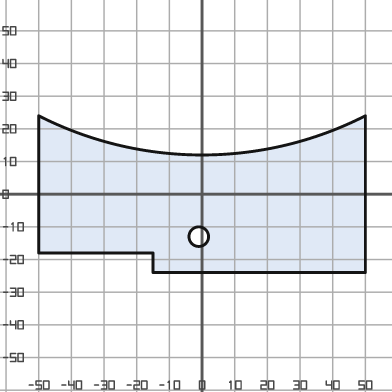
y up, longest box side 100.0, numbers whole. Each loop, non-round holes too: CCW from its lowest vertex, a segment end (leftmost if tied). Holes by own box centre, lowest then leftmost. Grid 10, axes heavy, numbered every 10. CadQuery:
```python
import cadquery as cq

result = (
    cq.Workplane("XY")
    .moveTo(-15.0, -24.0)
    .lineTo(50.0, -24.0)
    .lineTo(50.0, 24.0)
    .threePointArc((0.0, 12.0), (-50.0, 24.0))
    .lineTo(-50.0, -18.0)
    .lineTo(-15.0, -18.0)
    .close()
    .moveTo(-1.0, -13.0)
    .circle(3.0)
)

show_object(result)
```